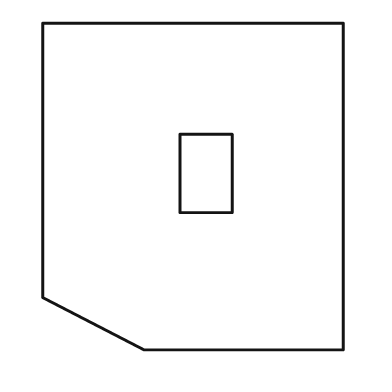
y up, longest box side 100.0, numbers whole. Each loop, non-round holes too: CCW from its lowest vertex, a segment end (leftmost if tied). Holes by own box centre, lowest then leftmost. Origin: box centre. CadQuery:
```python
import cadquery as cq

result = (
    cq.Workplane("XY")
    .moveTo(-15.0, -50.0)
    .lineTo(46.0, -50.0)
    .lineTo(46.0, 50.0)
    .lineTo(-46.0, 50.0)
    .lineTo(-46.0, -34.0)
    .close()
    .moveTo(-4.0, -8.0)
    .lineTo(12.0, -8.0)
    .lineTo(12.0, 16.0)
    .lineTo(-4.0, 16.0)
    .close()
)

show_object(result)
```